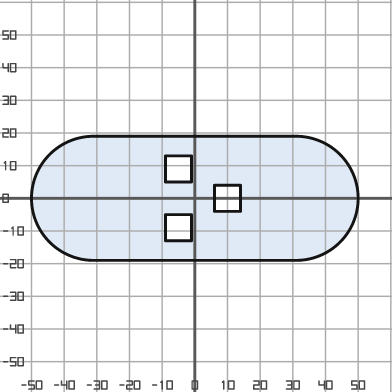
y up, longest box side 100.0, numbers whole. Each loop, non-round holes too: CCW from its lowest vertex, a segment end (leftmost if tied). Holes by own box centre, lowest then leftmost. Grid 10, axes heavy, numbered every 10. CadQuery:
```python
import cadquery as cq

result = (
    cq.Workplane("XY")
    .moveTo(-31.0, -19.0)
    .lineTo(31.0, -19.0)
    .threePointArc((50.0, 0.0), (31.0, 19.0))
    .lineTo(-31.0, 19.0)
    .threePointArc((-50.0, 0.0), (-31.0, -19.0))
    .close()
    .moveTo(-9.0, -13.0)
    .lineTo(-1.0, -13.0)
    .lineTo(-1.0, -5.0)
    .lineTo(-9.0, -5.0)
    .close()
    .moveTo(6.0, -4.0)
    .lineTo(14.0, -4.0)
    .lineTo(14.0, 4.0)
    .lineTo(6.0, 4.0)
    .close()
    .moveTo(-9.0, 5.0)
    .lineTo(-1.0, 5.0)
    .lineTo(-1.0, 13.0)
    .lineTo(-9.0, 13.0)
    .close()
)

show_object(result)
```